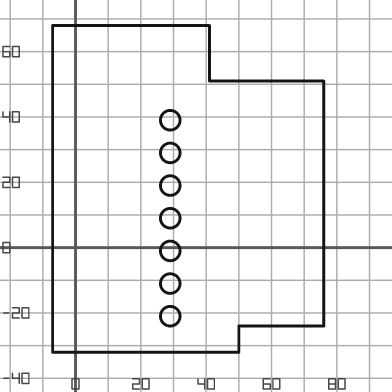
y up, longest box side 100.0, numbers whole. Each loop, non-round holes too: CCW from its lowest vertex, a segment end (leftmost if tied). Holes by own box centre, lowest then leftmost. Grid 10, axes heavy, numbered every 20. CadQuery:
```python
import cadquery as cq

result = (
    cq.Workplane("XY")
    .moveTo(-7.0, -32.0)
    .lineTo(50.0, -32.0)
    .lineTo(50.0, -24.0)
    .lineTo(76.0, -24.0)
    .lineTo(76.0, 51.0)
    .lineTo(41.0, 51.0)
    .lineTo(41.0, 68.0)
    .lineTo(-7.0, 68.0)
    .close()
    .moveTo(29.0, -21.0)
    .circle(3.0)
    .moveTo(29.0, -11.0)
    .circle(3.0)
    .moveTo(29.0, -1.0)
    .circle(3.0)
    .moveTo(29.0, 9.0)
    .circle(3.0)
    .moveTo(29.0, 19.0)
    .circle(3.0)
    .moveTo(29.0, 29.0)
    .circle(3.0)
    .moveTo(29.0, 39.0)
    .circle(3.0)
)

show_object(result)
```